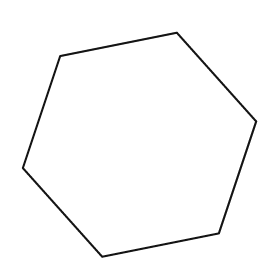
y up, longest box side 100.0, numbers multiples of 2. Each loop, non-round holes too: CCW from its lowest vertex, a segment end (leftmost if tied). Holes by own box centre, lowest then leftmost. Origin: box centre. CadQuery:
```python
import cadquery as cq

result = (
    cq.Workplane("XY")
    .moveTo(-16.0, -48.0)
    .lineTo(34.0, -38.0)
    .lineTo(50.0, 10.0)
    .lineTo(16.0, 48.0)
    .lineTo(-34.0, 38.0)
    .lineTo(-50.0, -10.0)
    .close()
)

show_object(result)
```